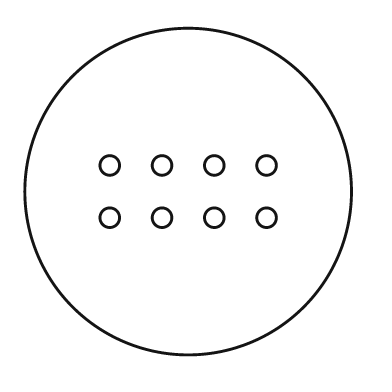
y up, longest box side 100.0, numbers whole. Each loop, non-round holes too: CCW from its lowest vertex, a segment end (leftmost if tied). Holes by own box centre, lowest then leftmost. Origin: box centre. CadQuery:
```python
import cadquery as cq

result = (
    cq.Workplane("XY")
    .moveTo(0.0, 0.0)
    .circle(50.0)
    .moveTo(-24.0, -8.0)
    .circle(3.0)
    .moveTo(-8.0, -8.0)
    .circle(3.0)
    .moveTo(8.0, -8.0)
    .circle(3.0)
    .moveTo(24.0, -8.0)
    .circle(3.0)
    .moveTo(-24.0, 8.0)
    .circle(3.0)
    .moveTo(-8.0, 8.0)
    .circle(3.0)
    .moveTo(8.0, 8.0)
    .circle(3.0)
    .moveTo(24.0, 8.0)
    .circle(3.0)
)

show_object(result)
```